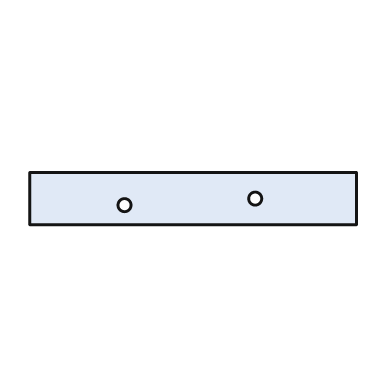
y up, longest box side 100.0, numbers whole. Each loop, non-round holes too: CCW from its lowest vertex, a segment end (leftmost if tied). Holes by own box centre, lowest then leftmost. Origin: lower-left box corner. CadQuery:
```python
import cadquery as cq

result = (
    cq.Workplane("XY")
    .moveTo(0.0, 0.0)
    .lineTo(100.0, 0.0)
    .lineTo(100.0, 16.0)
    .lineTo(0.0, 16.0)
    .close()
    .moveTo(29.0, 6.0)
    .circle(2.0)
    .moveTo(69.0, 8.0)
    .circle(2.0)
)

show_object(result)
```